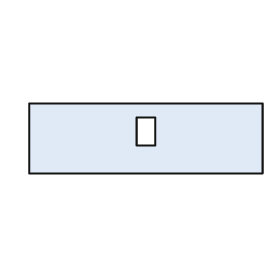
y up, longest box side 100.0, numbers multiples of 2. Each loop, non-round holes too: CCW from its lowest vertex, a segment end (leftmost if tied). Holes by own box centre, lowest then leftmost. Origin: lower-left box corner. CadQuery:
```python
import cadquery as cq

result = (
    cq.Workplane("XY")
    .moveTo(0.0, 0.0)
    .lineTo(100.0, 0.0)
    .lineTo(100.0, 30.0)
    .lineTo(0.0, 30.0)
    .close()
    .moveTo(46.0, 12.0)
    .lineTo(54.0, 12.0)
    .lineTo(54.0, 24.0)
    .lineTo(46.0, 24.0)
    .close()
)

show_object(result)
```